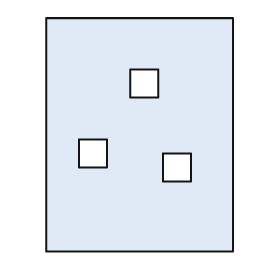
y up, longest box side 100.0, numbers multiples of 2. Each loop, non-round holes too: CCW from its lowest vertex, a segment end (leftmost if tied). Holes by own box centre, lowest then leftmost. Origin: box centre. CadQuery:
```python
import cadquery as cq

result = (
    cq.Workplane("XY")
    .moveTo(-40.0, -50.0)
    .lineTo(40.0, -50.0)
    .lineTo(40.0, 50.0)
    .lineTo(-40.0, 50.0)
    .close()
    .moveTo(10.0, -20.0)
    .lineTo(22.0, -20.0)
    .lineTo(22.0, -8.0)
    .lineTo(10.0, -8.0)
    .close()
    .moveTo(-26.0, -14.0)
    .lineTo(-14.0, -14.0)
    .lineTo(-14.0, -2.0)
    .lineTo(-26.0, -2.0)
    .close()
    .moveTo(-4.0, 16.0)
    .lineTo(8.0, 16.0)
    .lineTo(8.0, 28.0)
    .lineTo(-4.0, 28.0)
    .close()
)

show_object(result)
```